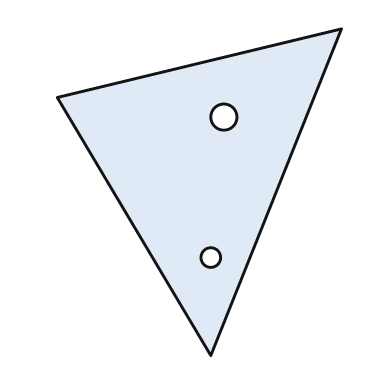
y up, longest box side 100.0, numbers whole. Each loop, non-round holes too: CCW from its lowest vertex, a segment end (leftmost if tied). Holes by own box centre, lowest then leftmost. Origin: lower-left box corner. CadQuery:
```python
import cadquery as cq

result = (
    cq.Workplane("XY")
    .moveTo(47.0, 0.0)
    .lineTo(87.0, 100.0)
    .lineTo(0.0, 79.0)
    .close()
    .moveTo(47.0, 30.0)
    .circle(3.0)
    .moveTo(51.0, 73.0)
    .circle(4.0)
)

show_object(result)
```